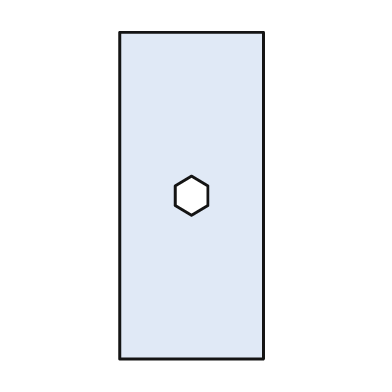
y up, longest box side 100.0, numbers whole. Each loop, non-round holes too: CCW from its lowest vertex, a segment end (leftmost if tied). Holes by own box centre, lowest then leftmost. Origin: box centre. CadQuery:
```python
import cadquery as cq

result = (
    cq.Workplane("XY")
    .moveTo(-22.0, -50.0)
    .lineTo(22.0, -50.0)
    .lineTo(22.0, 50.0)
    .lineTo(-22.0, 50.0)
    .close()
    .moveTo(0.0, -6.0)
    .lineTo(5.0, -3.0)
    .lineTo(5.0, 3.0)
    .lineTo(0.0, 6.0)
    .lineTo(-5.0, 3.0)
    .lineTo(-5.0, -3.0)
    .close()
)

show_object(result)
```